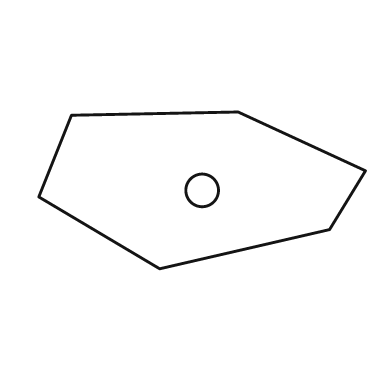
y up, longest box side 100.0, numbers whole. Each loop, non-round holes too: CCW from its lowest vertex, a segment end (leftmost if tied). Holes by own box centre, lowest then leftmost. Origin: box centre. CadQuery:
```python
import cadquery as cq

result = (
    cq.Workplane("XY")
    .moveTo(-13.0, -24.0)
    .lineTo(39.0, -12.0)
    .lineTo(50.0, 6.0)
    .lineTo(11.0, 24.0)
    .lineTo(-40.0, 23.0)
    .lineTo(-50.0, -2.0)
    .close()
    .moveTo(0.0, 0.0)
    .circle(5.0)
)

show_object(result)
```